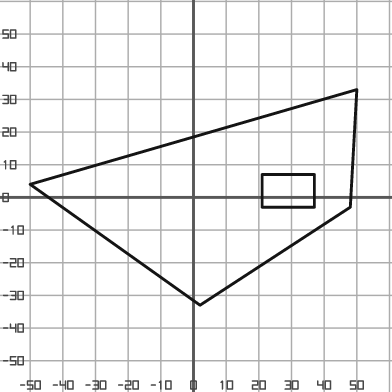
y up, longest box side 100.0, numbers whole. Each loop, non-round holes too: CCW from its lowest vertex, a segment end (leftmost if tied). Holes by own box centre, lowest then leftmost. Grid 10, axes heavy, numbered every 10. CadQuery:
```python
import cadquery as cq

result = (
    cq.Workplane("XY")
    .moveTo(2.0, -33.0)
    .lineTo(48.0, -3.0)
    .lineTo(50.0, 33.0)
    .lineTo(-50.0, 4.0)
    .close()
    .moveTo(21.0, -3.0)
    .lineTo(37.0, -3.0)
    .lineTo(37.0, 7.0)
    .lineTo(21.0, 7.0)
    .close()
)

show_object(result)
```